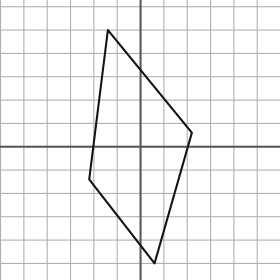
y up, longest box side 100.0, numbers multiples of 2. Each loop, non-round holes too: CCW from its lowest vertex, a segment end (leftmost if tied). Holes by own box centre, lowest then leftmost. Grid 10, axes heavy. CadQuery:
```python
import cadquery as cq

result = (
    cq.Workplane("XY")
    .moveTo(6.0, -50.0)
    .lineTo(22.0, 6.0)
    .lineTo(-14.0, 50.0)
    .lineTo(-22.0, -14.0)
    .close()
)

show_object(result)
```